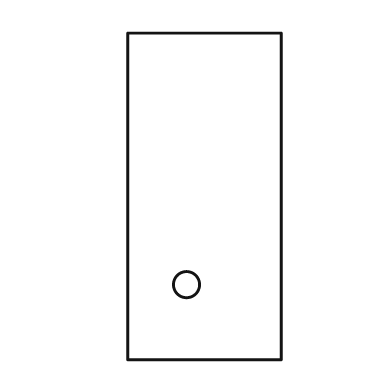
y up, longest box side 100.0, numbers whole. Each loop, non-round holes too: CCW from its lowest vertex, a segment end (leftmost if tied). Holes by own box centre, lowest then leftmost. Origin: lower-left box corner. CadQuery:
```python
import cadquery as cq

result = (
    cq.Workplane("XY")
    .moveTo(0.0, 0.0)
    .lineTo(47.0, 0.0)
    .lineTo(47.0, 100.0)
    .lineTo(0.0, 100.0)
    .close()
    .moveTo(18.0, 23.0)
    .circle(4.0)
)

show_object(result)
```